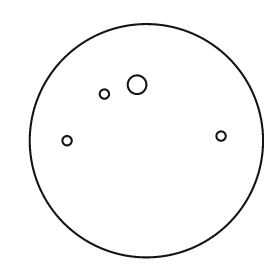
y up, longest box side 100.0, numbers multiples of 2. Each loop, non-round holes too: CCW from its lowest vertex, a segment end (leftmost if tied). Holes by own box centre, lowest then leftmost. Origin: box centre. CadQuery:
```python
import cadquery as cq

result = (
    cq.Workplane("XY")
    .moveTo(0.0, 0.0)
    .circle(50.0)
    .moveTo(-34.0, 0.0)
    .circle(2.0)
    .moveTo(32.0, 2.0)
    .circle(2.0)
    .moveTo(-18.0, 20.0)
    .circle(2.0)
    .moveTo(-4.0, 24.0)
    .circle(4.0)
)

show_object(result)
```